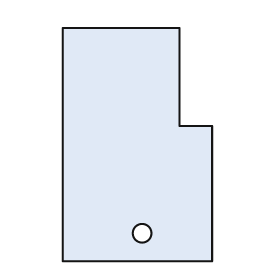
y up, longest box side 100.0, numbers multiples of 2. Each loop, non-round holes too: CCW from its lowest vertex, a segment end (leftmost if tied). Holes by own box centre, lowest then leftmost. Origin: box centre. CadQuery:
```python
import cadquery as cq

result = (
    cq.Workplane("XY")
    .moveTo(-32.0, -50.0)
    .lineTo(32.0, -50.0)
    .lineTo(32.0, 8.0)
    .lineTo(18.0, 8.0)
    .lineTo(18.0, 50.0)
    .lineTo(-32.0, 50.0)
    .close()
    .moveTo(2.0, -38.0)
    .circle(4.0)
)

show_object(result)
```